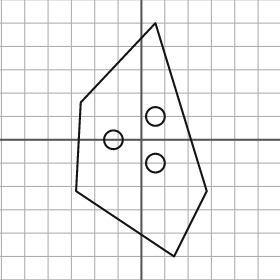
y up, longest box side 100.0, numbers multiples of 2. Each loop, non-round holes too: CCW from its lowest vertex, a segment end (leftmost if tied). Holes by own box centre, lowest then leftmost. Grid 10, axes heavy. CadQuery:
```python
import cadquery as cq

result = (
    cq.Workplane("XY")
    .moveTo(14.0, -50.0)
    .lineTo(28.0, -22.0)
    .lineTo(6.0, 50.0)
    .lineTo(-26.0, 16.0)
    .lineTo(-28.0, -22.0)
    .close()
    .moveTo(6.0, -10.0)
    .circle(4.0)
    .moveTo(-12.0, 0.0)
    .circle(4.0)
    .moveTo(6.0, 10.0)
    .circle(4.0)
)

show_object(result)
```